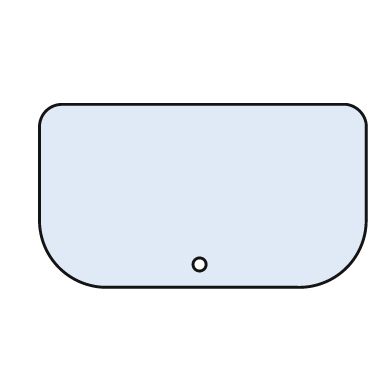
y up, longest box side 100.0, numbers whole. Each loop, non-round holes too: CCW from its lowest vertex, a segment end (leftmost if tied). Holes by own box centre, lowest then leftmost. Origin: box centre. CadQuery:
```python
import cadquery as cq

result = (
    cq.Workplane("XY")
    .moveTo(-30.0, -28.0)
    .lineTo(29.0, -28.0)
    .threePointArc((44.0, -22.0), (50.0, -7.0))
    .lineTo(50.0, 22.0)
    .threePointArc((48.0, 26.0), (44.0, 28.0))
    .lineTo(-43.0, 28.0)
    .threePointArc((-48.0, 26.0), (-50.0, 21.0))
    .lineTo(-50.0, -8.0)
    .threePointArc((-44.0, -22.0), (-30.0, -28.0))
    .close()
    .moveTo(-1.0, -21.0)
    .circle(2.0)
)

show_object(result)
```